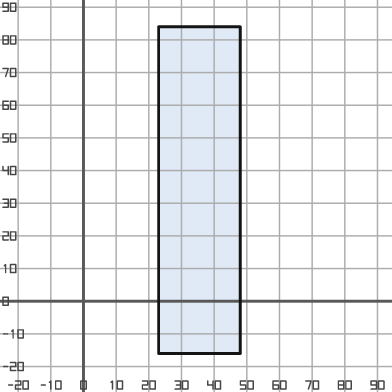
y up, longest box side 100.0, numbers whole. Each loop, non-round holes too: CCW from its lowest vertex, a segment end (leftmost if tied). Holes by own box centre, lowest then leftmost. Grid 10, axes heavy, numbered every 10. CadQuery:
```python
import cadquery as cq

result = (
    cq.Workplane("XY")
    .moveTo(23.0, -16.0)
    .lineTo(48.0, -16.0)
    .lineTo(48.0, 84.0)
    .lineTo(23.0, 84.0)
    .close()
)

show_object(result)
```